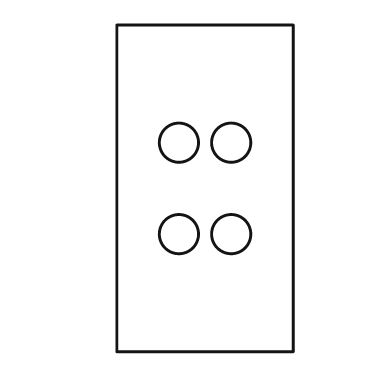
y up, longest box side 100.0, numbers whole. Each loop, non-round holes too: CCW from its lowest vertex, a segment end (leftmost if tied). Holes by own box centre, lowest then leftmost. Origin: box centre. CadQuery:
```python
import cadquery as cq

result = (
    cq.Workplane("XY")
    .moveTo(-27.0, -50.0)
    .lineTo(27.0, -50.0)
    .lineTo(27.0, 50.0)
    .lineTo(-27.0, 50.0)
    .close()
    .moveTo(-8.0, -14.0)
    .circle(6.0)
    .moveTo(8.0, -14.0)
    .circle(6.0)
    .moveTo(-8.0, 14.0)
    .circle(6.0)
    .moveTo(8.0, 14.0)
    .circle(6.0)
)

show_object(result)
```